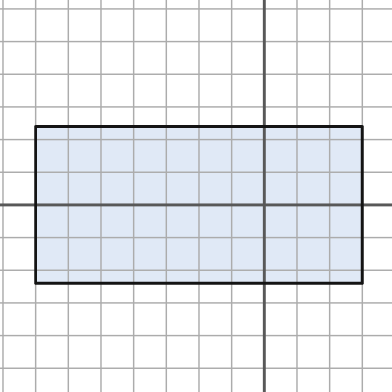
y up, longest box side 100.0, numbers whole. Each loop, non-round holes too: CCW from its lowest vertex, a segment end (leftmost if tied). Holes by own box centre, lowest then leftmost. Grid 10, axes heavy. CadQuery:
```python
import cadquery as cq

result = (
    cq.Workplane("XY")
    .moveTo(-70.0, -24.0)
    .lineTo(30.0, -24.0)
    .lineTo(30.0, 24.0)
    .lineTo(-70.0, 24.0)
    .close()
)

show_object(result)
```